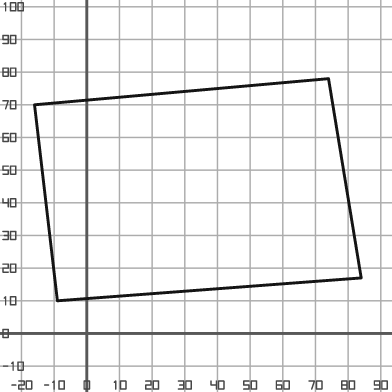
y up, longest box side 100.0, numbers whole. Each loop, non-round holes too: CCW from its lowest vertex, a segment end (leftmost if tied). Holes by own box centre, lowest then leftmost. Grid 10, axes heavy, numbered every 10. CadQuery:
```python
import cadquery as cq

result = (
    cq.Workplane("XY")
    .moveTo(-9.0, 10.0)
    .lineTo(84.0, 17.0)
    .lineTo(74.0, 78.0)
    .lineTo(-16.0, 70.0)
    .close()
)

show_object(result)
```